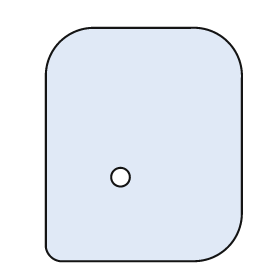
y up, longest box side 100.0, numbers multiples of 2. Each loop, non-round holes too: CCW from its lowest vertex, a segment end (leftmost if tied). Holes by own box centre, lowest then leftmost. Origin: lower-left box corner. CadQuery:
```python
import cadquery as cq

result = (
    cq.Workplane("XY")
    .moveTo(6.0, 0.0)
    .lineTo(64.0, 0.0)
    .threePointArc((78.0, 6.0), (84.0, 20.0))
    .lineTo(84.0, 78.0)
    .threePointArc((78.0, 94.0), (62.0, 100.0))
    .lineTo(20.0, 100.0)
    .threePointArc((6.0, 94.0), (0.0, 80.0))
    .lineTo(0.0, 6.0)
    .threePointArc((2.0, 2.0), (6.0, 0.0))
    .close()
    .moveTo(32.0, 36.0)
    .circle(4.0)
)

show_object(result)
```